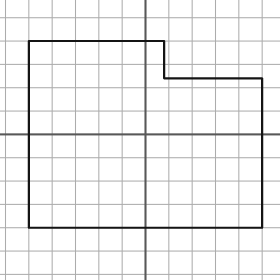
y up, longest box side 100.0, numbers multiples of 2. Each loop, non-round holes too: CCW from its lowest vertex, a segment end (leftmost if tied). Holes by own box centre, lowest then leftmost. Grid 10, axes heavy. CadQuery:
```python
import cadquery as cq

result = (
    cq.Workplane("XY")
    .moveTo(-50.0, -40.0)
    .lineTo(50.0, -40.0)
    .lineTo(50.0, 24.0)
    .lineTo(8.0, 24.0)
    .lineTo(8.0, 40.0)
    .lineTo(-50.0, 40.0)
    .close()
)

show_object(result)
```